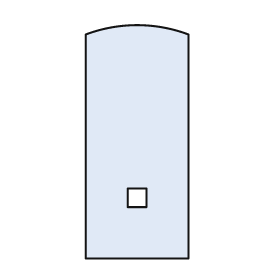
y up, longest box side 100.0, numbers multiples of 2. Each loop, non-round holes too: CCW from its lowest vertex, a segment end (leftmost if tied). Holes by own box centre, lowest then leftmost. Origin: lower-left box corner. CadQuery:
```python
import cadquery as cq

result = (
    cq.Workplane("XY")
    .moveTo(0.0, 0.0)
    .lineTo(44.0, 0.0)
    .lineTo(44.0, 96.0)
    .threePointArc((22.0, 100.0), (0.0, 96.0))
    .close()
    .moveTo(18.0, 22.0)
    .lineTo(26.0, 22.0)
    .lineTo(26.0, 30.0)
    .lineTo(18.0, 30.0)
    .close()
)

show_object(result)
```